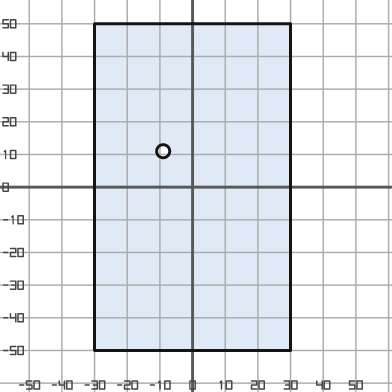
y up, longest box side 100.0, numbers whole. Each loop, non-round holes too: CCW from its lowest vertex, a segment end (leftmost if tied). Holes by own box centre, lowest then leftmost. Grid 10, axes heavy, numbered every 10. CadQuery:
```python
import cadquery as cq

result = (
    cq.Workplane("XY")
    .moveTo(-30.0, -50.0)
    .lineTo(30.0, -50.0)
    .lineTo(30.0, 50.0)
    .lineTo(-30.0, 50.0)
    .close()
    .moveTo(-9.0, 11.0)
    .circle(2.0)
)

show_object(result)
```